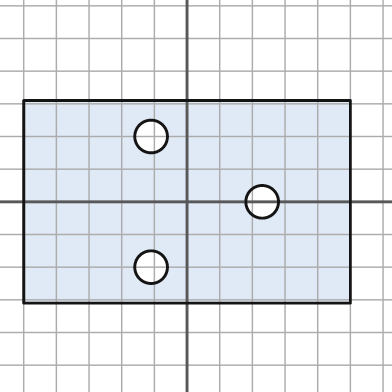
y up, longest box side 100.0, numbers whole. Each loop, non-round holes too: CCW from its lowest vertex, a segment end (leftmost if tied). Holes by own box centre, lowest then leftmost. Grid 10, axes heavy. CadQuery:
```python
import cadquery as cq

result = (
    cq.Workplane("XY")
    .moveTo(-50.0, -31.0)
    .lineTo(50.0, -31.0)
    .lineTo(50.0, 31.0)
    .lineTo(-50.0, 31.0)
    .close()
    .moveTo(-11.0, -20.0)
    .circle(5.0)
    .moveTo(23.0, 0.0)
    .circle(5.0)
    .moveTo(-11.0, 20.0)
    .circle(5.0)
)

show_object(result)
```